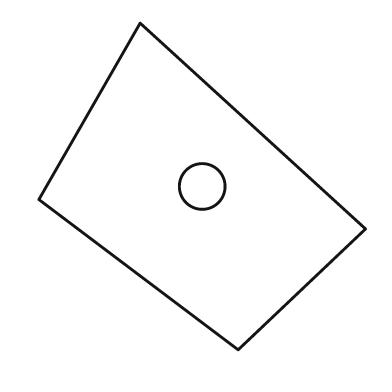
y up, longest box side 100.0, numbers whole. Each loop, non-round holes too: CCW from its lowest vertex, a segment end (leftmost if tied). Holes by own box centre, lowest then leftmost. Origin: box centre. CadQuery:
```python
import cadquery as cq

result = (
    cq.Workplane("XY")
    .moveTo(11.0, -50.0)
    .lineTo(50.0, -13.0)
    .lineTo(-19.0, 50.0)
    .lineTo(-50.0, -4.0)
    .close()
    .moveTo(0.0, 0.0)
    .circle(7.0)
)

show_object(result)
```